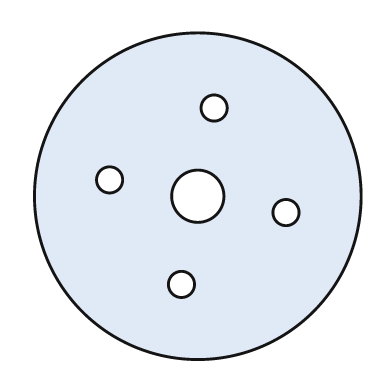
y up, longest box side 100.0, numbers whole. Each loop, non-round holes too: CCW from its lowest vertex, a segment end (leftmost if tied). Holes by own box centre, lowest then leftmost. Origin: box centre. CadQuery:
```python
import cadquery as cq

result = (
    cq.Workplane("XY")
    .moveTo(0.0, 0.0)
    .circle(50.0)
    .moveTo(-5.0, -27.0)
    .circle(4.0)
    .moveTo(27.0, -5.0)
    .circle(4.0)
    .moveTo(0.0, 0.0)
    .circle(8.0)
    .moveTo(-27.0, 5.0)
    .circle(4.0)
    .moveTo(5.0, 27.0)
    .circle(4.0)
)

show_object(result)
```